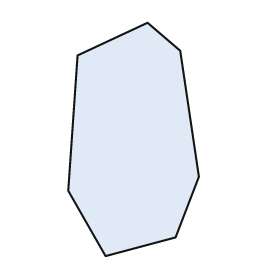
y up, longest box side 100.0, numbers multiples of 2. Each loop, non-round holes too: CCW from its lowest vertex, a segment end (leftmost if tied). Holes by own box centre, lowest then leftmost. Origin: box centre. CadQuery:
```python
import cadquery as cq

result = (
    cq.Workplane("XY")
    .moveTo(-12.0, -50.0)
    .lineTo(18.0, -42.0)
    .lineTo(28.0, -16.0)
    .lineTo(20.0, 38.0)
    .lineTo(6.0, 50.0)
    .lineTo(-24.0, 36.0)
    .lineTo(-28.0, -22.0)
    .close()
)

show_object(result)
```